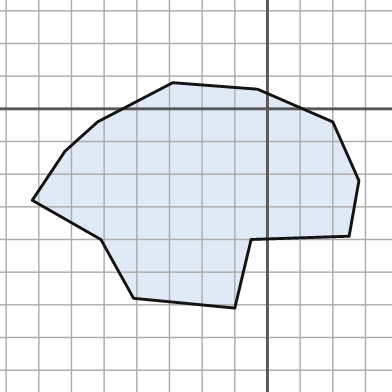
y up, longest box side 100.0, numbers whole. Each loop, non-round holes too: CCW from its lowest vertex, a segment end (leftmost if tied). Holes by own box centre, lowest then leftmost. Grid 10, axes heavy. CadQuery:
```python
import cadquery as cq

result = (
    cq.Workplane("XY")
    .moveTo(-10.0, -61.0)
    .lineTo(-5.0, -40.0)
    .lineTo(25.0, -39.0)
    .lineTo(28.0, -22.0)
    .lineTo(20.0, -4.0)
    .lineTo(-3.0, 6.0)
    .lineTo(-29.0, 8.0)
    .lineTo(-52.0, -4.0)
    .lineTo(-62.0, -13.0)
    .lineTo(-72.0, -28.0)
    .lineTo(-51.0, -40.0)
    .lineTo(-41.0, -58.0)
    .close()
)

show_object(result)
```